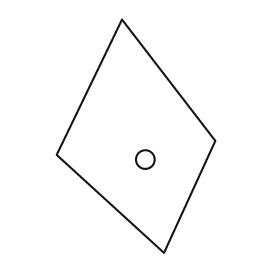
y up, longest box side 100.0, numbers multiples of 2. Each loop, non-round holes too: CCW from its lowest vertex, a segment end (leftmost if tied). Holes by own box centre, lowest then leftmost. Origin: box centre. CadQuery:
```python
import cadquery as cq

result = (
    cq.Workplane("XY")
    .moveTo(12.0, -50.0)
    .lineTo(34.0, -2.0)
    .lineTo(-6.0, 50.0)
    .lineTo(-34.0, -8.0)
    .close()
    .moveTo(4.0, -10.0)
    .circle(4.0)
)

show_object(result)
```